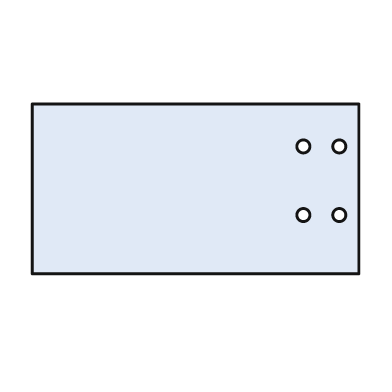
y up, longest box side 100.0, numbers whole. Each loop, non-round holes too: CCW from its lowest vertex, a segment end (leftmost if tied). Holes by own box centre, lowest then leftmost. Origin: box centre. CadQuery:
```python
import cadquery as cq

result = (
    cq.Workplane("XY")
    .moveTo(-50.0, -26.0)
    .lineTo(50.0, -26.0)
    .lineTo(50.0, 26.0)
    .lineTo(-50.0, 26.0)
    .close()
    .moveTo(33.0, -8.0)
    .circle(2.0)
    .moveTo(44.0, -8.0)
    .circle(2.0)
    .moveTo(33.0, 13.0)
    .circle(2.0)
    .moveTo(44.0, 13.0)
    .circle(2.0)
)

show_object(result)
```